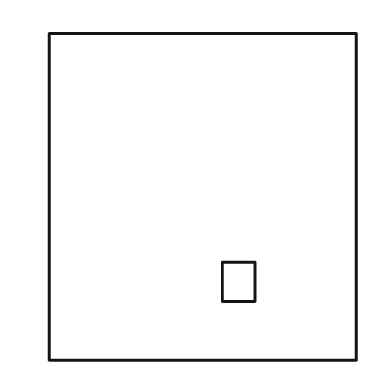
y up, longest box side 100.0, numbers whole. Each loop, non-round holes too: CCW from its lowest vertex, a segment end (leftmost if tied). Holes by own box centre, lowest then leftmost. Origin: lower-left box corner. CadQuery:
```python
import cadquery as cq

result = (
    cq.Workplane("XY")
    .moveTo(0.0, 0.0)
    .lineTo(94.0, 0.0)
    .lineTo(94.0, 100.0)
    .lineTo(0.0, 100.0)
    .close()
    .moveTo(53.0, 18.0)
    .lineTo(63.0, 18.0)
    .lineTo(63.0, 30.0)
    .lineTo(53.0, 30.0)
    .close()
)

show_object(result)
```